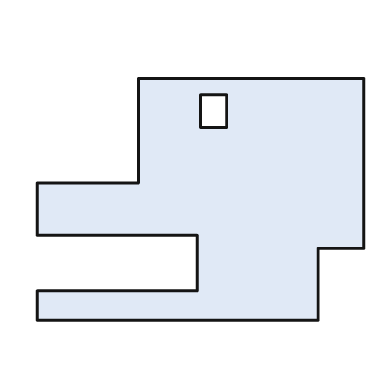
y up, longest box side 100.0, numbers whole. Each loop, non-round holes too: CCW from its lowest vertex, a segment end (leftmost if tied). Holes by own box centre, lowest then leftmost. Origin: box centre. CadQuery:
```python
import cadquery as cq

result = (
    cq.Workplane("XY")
    .moveTo(-50.0, -37.0)
    .lineTo(36.0, -37.0)
    .lineTo(36.0, -15.0)
    .lineTo(50.0, -15.0)
    .lineTo(50.0, 37.0)
    .lineTo(-19.0, 37.0)
    .lineTo(-19.0, 5.0)
    .lineTo(-50.0, 5.0)
    .lineTo(-50.0, -11.0)
    .lineTo(-1.0, -11.0)
    .lineTo(-1.0, -28.0)
    .lineTo(-50.0, -28.0)
    .close()
    .moveTo(0.0, 22.0)
    .lineTo(8.0, 22.0)
    .lineTo(8.0, 32.0)
    .lineTo(0.0, 32.0)
    .close()
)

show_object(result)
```